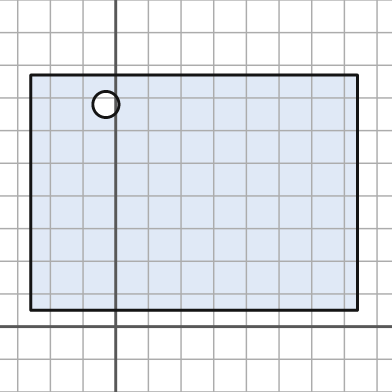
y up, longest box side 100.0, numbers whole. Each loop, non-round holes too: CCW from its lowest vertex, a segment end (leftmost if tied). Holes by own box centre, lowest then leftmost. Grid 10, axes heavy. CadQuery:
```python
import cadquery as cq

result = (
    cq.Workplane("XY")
    .moveTo(-26.0, 5.0)
    .lineTo(74.0, 5.0)
    .lineTo(74.0, 77.0)
    .lineTo(-26.0, 77.0)
    .close()
    .moveTo(-3.0, 68.0)
    .circle(4.0)
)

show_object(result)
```